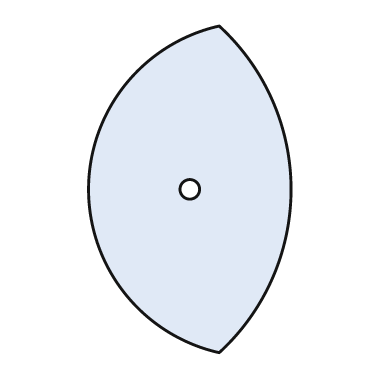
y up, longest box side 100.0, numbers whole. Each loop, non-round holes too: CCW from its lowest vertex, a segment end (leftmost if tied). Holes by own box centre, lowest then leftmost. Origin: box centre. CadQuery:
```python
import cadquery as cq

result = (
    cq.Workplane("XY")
    .moveTo(9.0, -50.0)
    .threePointArc((31.0, 0.0), (9.0, 50.0))
    .threePointArc((-31.0, 0.0), (9.0, -50.0))
    .close()
    .moveTo(0.0, 0.0)
    .circle(3.0)
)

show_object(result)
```